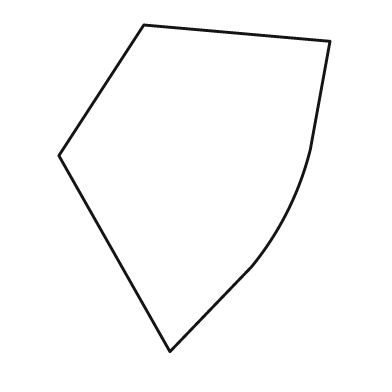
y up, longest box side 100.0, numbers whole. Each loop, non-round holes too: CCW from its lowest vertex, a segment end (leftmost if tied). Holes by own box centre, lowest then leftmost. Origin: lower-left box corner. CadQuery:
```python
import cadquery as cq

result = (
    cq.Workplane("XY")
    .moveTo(34.0, 0.0)
    .lineTo(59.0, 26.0)
    .threePointArc((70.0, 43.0), (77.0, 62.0))
    .lineTo(83.0, 95.0)
    .lineTo(26.0, 100.0)
    .lineTo(0.0, 60.0)
    .close()
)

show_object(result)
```